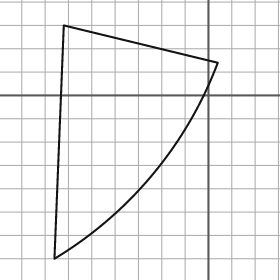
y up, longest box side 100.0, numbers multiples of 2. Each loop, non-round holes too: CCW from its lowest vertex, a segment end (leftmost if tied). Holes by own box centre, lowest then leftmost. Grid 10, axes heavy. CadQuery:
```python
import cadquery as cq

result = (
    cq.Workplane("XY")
    .moveTo(-66.0, -70.0)
    .threePointArc((-24.0, -34.0), (4.0, 14.0))
    .lineTo(-62.0, 30.0)
    .close()
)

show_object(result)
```